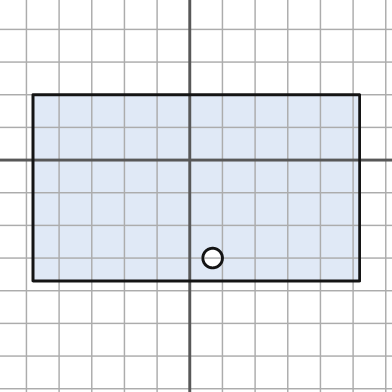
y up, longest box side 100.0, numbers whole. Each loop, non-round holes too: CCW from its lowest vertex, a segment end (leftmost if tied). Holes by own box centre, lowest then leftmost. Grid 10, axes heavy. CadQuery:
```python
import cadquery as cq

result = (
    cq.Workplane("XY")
    .moveTo(-48.0, -37.0)
    .lineTo(52.0, -37.0)
    .lineTo(52.0, 20.0)
    .lineTo(-48.0, 20.0)
    .close()
    .moveTo(7.0, -30.0)
    .circle(3.0)
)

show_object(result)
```